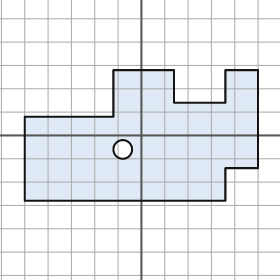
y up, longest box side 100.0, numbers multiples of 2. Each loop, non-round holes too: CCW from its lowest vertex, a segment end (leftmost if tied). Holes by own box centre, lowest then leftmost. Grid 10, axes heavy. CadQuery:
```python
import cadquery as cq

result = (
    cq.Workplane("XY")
    .moveTo(-50.0, -28.0)
    .lineTo(36.0, -28.0)
    .lineTo(36.0, -14.0)
    .lineTo(50.0, -14.0)
    .lineTo(50.0, 28.0)
    .lineTo(36.0, 28.0)
    .lineTo(36.0, 14.0)
    .lineTo(14.0, 14.0)
    .lineTo(14.0, 28.0)
    .lineTo(-12.0, 28.0)
    .lineTo(-12.0, 8.0)
    .lineTo(-50.0, 8.0)
    .close()
    .moveTo(-8.0, -6.0)
    .circle(4.0)
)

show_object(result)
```